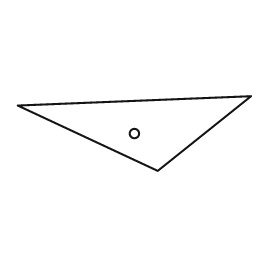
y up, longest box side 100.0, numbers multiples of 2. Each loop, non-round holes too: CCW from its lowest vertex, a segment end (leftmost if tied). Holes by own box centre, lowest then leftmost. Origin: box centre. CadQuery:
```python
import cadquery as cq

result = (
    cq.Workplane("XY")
    .moveTo(10.0, -16.0)
    .lineTo(50.0, 16.0)
    .lineTo(-50.0, 12.0)
    .close()
    .moveTo(0.0, 0.0)
    .circle(2.0)
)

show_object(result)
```